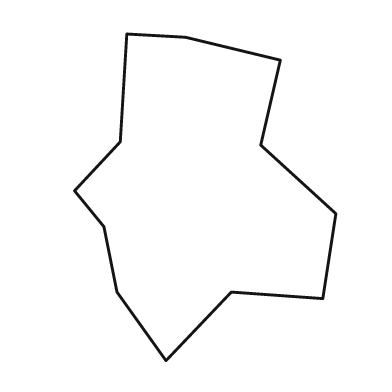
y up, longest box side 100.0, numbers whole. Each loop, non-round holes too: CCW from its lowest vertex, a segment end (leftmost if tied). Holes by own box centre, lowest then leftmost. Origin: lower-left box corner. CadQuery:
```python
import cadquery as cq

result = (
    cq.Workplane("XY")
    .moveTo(28.0, 0.0)
    .lineTo(48.0, 21.0)
    .lineTo(76.0, 19.0)
    .lineTo(80.0, 45.0)
    .lineTo(57.0, 66.0)
    .lineTo(63.0, 92.0)
    .lineTo(34.0, 99.0)
    .lineTo(16.0, 100.0)
    .lineTo(14.0, 67.0)
    .lineTo(0.0, 52.0)
    .lineTo(9.0, 41.0)
    .lineTo(13.0, 21.0)
    .close()
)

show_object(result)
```